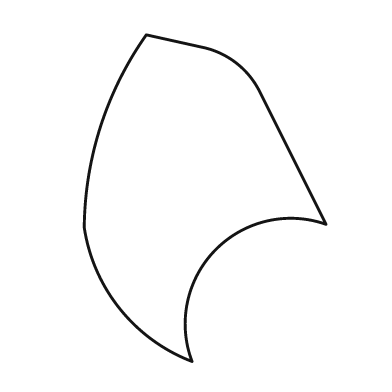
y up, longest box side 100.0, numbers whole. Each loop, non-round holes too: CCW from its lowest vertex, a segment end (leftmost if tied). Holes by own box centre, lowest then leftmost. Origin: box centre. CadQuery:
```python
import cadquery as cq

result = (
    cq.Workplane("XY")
    .moveTo(-4.0, -50.0)
    .threePointArc((3.0, -16.0), (37.0, -8.0))
    .lineTo(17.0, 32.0)
    .threePointArc((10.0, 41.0), (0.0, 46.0))
    .lineTo(-18.0, 50.0)
    .threePointArc((-32.0, 22.0), (-37.0, -9.0))
    .threePointArc((-26.0, -34.0), (-4.0, -50.0))
    .close()
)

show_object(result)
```